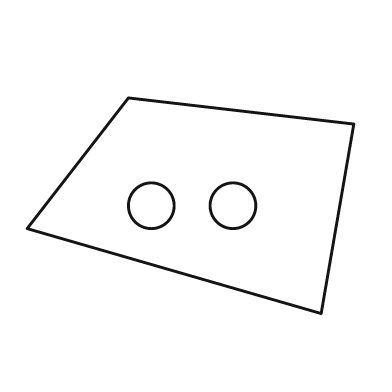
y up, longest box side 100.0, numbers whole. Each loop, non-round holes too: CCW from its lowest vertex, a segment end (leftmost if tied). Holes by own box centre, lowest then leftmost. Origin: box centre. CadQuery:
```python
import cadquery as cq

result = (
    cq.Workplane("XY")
    .moveTo(40.0, -33.0)
    .lineTo(50.0, 25.0)
    .lineTo(-19.0, 33.0)
    .lineTo(-50.0, -7.0)
    .close()
    .moveTo(-12.0, 0.0)
    .circle(7.0)
    .moveTo(13.0, 0.0)
    .circle(7.0)
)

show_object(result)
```